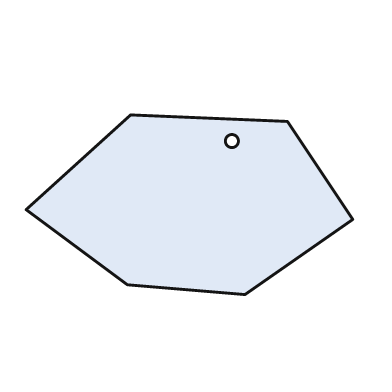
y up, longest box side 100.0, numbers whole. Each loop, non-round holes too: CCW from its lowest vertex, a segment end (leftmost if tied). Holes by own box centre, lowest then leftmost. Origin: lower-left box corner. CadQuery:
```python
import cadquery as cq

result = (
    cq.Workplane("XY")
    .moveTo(67.0, 0.0)
    .lineTo(100.0, 23.0)
    .lineTo(80.0, 53.0)
    .lineTo(32.0, 55.0)
    .lineTo(0.0, 26.0)
    .lineTo(31.0, 3.0)
    .close()
    .moveTo(63.0, 47.0)
    .circle(2.0)
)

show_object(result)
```